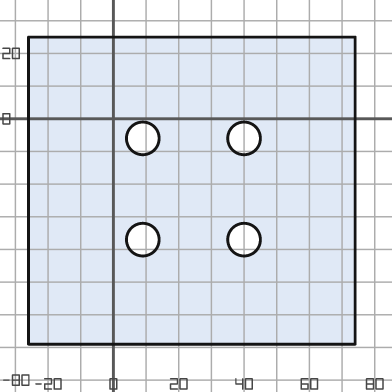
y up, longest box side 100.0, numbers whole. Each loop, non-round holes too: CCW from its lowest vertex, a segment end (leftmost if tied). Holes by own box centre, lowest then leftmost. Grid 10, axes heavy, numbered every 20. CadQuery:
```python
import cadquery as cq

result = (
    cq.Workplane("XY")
    .moveTo(-26.0, -69.0)
    .lineTo(74.0, -69.0)
    .lineTo(74.0, 25.0)
    .lineTo(-26.0, 25.0)
    .close()
    .moveTo(9.0, -37.0)
    .circle(5.0)
    .moveTo(40.0, -37.0)
    .circle(5.0)
    .moveTo(9.0, -6.0)
    .circle(5.0)
    .moveTo(40.0, -6.0)
    .circle(5.0)
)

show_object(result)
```